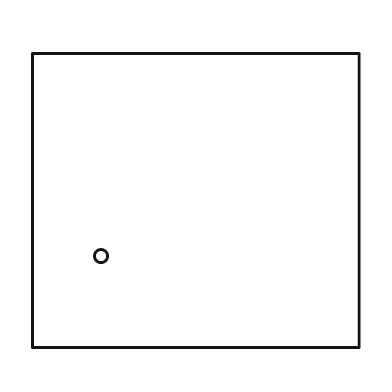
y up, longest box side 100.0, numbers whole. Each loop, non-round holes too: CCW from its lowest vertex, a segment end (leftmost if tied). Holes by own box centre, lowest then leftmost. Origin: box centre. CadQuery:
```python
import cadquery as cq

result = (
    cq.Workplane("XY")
    .moveTo(-50.0, -45.0)
    .lineTo(50.0, -45.0)
    .lineTo(50.0, 45.0)
    .lineTo(-50.0, 45.0)
    .close()
    .moveTo(-29.0, -17.0)
    .circle(2.0)
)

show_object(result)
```